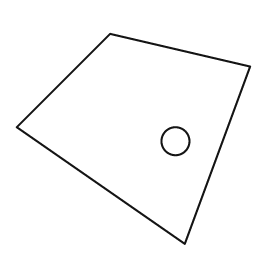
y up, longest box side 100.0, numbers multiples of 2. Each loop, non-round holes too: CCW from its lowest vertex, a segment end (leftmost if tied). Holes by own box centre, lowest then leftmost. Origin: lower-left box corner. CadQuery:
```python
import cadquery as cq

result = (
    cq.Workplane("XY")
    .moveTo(72.0, 0.0)
    .lineTo(100.0, 76.0)
    .lineTo(40.0, 90.0)
    .lineTo(0.0, 50.0)
    .close()
    .moveTo(68.0, 44.0)
    .circle(6.0)
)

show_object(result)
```